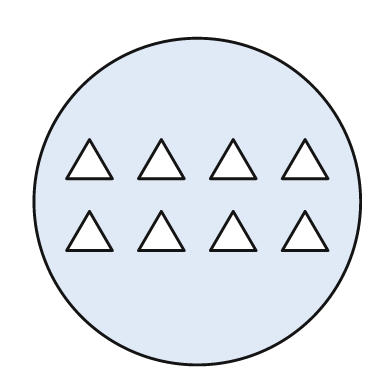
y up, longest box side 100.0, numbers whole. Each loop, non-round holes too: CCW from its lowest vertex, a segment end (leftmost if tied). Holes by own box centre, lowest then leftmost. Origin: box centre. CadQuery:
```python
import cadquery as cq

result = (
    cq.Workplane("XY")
    .moveTo(0.0, 0.0)
    .circle(50.0)
    .moveTo(-40.0, -15.0)
    .lineTo(-26.0, -15.0)
    .lineTo(-33.0, -3.0)
    .close()
    .moveTo(-18.0, -15.0)
    .lineTo(-4.0, -15.0)
    .lineTo(-11.0, -3.0)
    .close()
    .moveTo(4.0, -15.0)
    .lineTo(18.0, -15.0)
    .lineTo(11.0, -3.0)
    .close()
    .moveTo(26.0, -15.0)
    .lineTo(40.0, -15.0)
    .lineTo(33.0, -3.0)
    .close()
    .moveTo(-40.0, 7.0)
    .lineTo(-26.0, 7.0)
    .lineTo(-33.0, 19.0)
    .close()
    .moveTo(-18.0, 7.0)
    .lineTo(-4.0, 7.0)
    .lineTo(-11.0, 19.0)
    .close()
    .moveTo(4.0, 7.0)
    .lineTo(18.0, 7.0)
    .lineTo(11.0, 19.0)
    .close()
    .moveTo(26.0, 7.0)
    .lineTo(40.0, 7.0)
    .lineTo(33.0, 19.0)
    .close()
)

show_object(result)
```